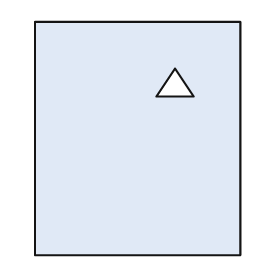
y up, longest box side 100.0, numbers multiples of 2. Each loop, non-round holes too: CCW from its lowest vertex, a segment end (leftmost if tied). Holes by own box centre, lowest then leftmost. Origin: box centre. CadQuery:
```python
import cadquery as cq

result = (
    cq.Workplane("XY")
    .moveTo(-44.0, -50.0)
    .lineTo(44.0, -50.0)
    .lineTo(44.0, 50.0)
    .lineTo(-44.0, 50.0)
    .close()
    .moveTo(8.0, 18.0)
    .lineTo(24.0, 18.0)
    .lineTo(16.0, 30.0)
    .close()
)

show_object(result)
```